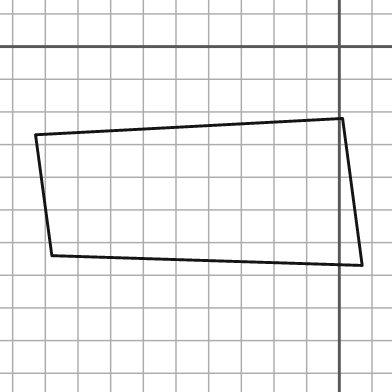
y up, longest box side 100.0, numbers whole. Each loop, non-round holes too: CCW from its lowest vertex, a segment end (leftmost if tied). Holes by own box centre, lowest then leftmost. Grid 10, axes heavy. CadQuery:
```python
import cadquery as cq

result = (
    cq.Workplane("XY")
    .moveTo(7.0, -67.0)
    .lineTo(1.0, -22.0)
    .lineTo(-93.0, -27.0)
    .lineTo(-88.0, -64.0)
    .close()
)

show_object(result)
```